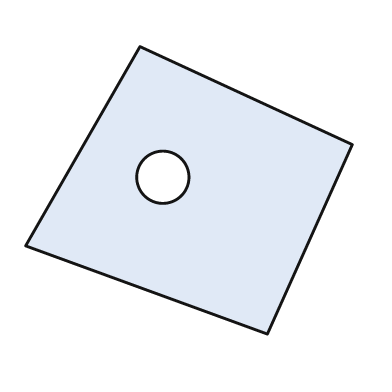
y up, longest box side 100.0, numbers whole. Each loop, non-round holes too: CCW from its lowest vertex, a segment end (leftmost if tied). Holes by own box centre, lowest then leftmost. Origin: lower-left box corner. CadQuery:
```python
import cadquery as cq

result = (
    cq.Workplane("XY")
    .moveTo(74.0, 0.0)
    .lineTo(100.0, 58.0)
    .lineTo(35.0, 88.0)
    .lineTo(0.0, 27.0)
    .close()
    .moveTo(42.0, 48.0)
    .circle(8.0)
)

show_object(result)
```